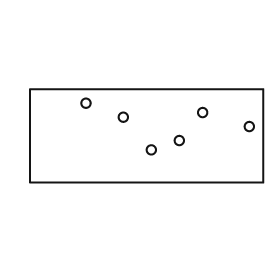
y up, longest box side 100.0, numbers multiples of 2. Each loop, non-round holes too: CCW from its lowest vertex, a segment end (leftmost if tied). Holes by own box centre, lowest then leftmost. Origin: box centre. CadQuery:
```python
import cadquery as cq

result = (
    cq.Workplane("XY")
    .moveTo(-50.0, -20.0)
    .lineTo(50.0, -20.0)
    .lineTo(50.0, 20.0)
    .lineTo(-50.0, 20.0)
    .close()
    .moveTo(2.0, -6.0)
    .circle(2.0)
    .moveTo(14.0, -2.0)
    .circle(2.0)
    .moveTo(44.0, 4.0)
    .circle(2.0)
    .moveTo(-10.0, 8.0)
    .circle(2.0)
    .moveTo(24.0, 10.0)
    .circle(2.0)
    .moveTo(-26.0, 14.0)
    .circle(2.0)
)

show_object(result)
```